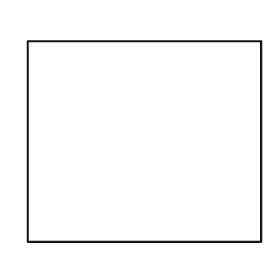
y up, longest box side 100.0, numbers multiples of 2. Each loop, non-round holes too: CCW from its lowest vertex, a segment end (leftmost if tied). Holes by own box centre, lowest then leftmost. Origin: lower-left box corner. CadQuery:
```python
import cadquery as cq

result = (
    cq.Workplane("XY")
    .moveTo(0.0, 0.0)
    .lineTo(100.0, 0.0)
    .lineTo(100.0, 86.0)
    .lineTo(0.0, 86.0)
    .close()
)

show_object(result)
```